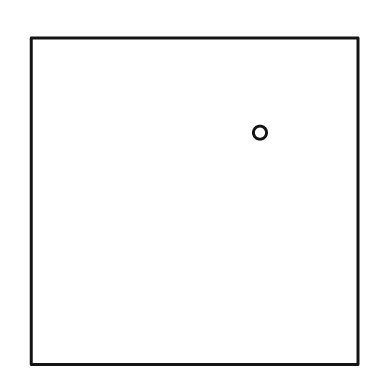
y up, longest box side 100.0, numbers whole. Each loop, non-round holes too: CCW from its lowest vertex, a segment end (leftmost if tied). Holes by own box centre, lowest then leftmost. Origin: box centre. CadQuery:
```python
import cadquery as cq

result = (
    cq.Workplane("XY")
    .moveTo(-50.0, -50.0)
    .lineTo(50.0, -50.0)
    .lineTo(50.0, 50.0)
    .lineTo(-50.0, 50.0)
    .close()
    .moveTo(20.0, 21.0)
    .circle(2.0)
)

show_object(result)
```